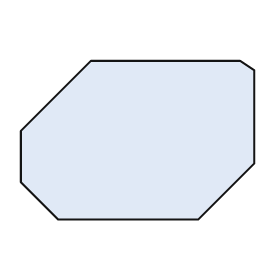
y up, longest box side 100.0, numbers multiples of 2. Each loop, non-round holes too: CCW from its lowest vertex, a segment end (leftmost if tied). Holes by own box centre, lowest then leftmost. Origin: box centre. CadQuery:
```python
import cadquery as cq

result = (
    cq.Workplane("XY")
    .moveTo(-34.0, -34.0)
    .lineTo(26.0, -34.0)
    .lineTo(50.0, -10.0)
    .lineTo(50.0, 30.0)
    .lineTo(44.0, 34.0)
    .lineTo(-20.0, 34.0)
    .lineTo(-50.0, 4.0)
    .lineTo(-50.0, -18.0)
    .close()
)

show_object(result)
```